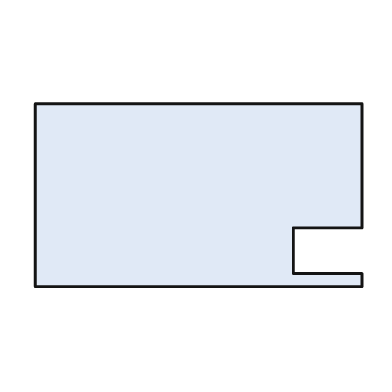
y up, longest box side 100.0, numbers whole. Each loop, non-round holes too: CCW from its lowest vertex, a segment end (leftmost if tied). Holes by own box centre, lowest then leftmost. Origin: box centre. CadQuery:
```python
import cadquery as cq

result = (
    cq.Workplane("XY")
    .moveTo(-50.0, -28.0)
    .lineTo(50.0, -28.0)
    .lineTo(50.0, -24.0)
    .lineTo(29.0, -24.0)
    .lineTo(29.0, -10.0)
    .lineTo(50.0, -10.0)
    .lineTo(50.0, 28.0)
    .lineTo(-50.0, 28.0)
    .close()
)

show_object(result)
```